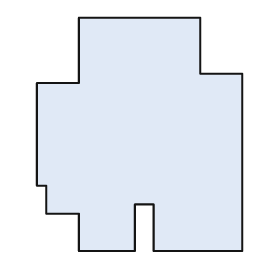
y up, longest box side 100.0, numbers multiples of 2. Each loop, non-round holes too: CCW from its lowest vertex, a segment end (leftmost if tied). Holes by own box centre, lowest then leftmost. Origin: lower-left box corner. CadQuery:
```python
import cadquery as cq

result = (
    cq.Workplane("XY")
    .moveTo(18.0, 0.0)
    .lineTo(42.0, 0.0)
    .lineTo(42.0, 20.0)
    .lineTo(50.0, 20.0)
    .lineTo(50.0, 0.0)
    .lineTo(88.0, 0.0)
    .lineTo(88.0, 76.0)
    .lineTo(70.0, 76.0)
    .lineTo(70.0, 100.0)
    .lineTo(18.0, 100.0)
    .lineTo(18.0, 72.0)
    .lineTo(0.0, 72.0)
    .lineTo(0.0, 28.0)
    .lineTo(4.0, 28.0)
    .lineTo(4.0, 16.0)
    .lineTo(18.0, 16.0)
    .close()
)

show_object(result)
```